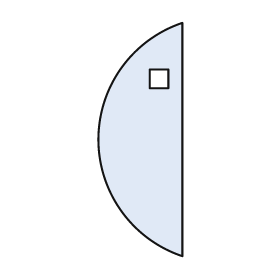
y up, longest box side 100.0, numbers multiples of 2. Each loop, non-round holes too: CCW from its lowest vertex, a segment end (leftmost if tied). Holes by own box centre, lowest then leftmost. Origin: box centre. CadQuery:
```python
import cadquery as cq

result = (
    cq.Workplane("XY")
    .moveTo(18.0, -50.0)
    .lineTo(18.0, 50.0)
    .threePointArc((-18.0, 0.0), (18.0, -50.0))
    .close()
    .moveTo(4.0, 22.0)
    .lineTo(12.0, 22.0)
    .lineTo(12.0, 30.0)
    .lineTo(4.0, 30.0)
    .close()
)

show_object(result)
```